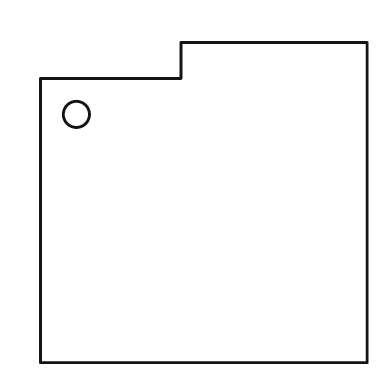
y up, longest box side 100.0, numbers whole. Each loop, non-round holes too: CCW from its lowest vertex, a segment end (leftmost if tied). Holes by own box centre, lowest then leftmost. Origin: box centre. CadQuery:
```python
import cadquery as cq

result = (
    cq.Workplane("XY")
    .moveTo(-50.0, -49.0)
    .lineTo(50.0, -49.0)
    .lineTo(50.0, 49.0)
    .lineTo(-7.0, 49.0)
    .lineTo(-7.0, 38.0)
    .lineTo(-50.0, 38.0)
    .close()
    .moveTo(-39.0, 27.0)
    .circle(4.0)
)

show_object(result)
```